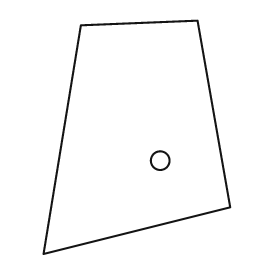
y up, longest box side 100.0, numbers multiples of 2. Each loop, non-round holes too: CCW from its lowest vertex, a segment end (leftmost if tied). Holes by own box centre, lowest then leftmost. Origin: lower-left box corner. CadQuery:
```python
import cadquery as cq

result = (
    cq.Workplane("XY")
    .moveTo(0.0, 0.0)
    .lineTo(80.0, 20.0)
    .lineTo(66.0, 100.0)
    .lineTo(16.0, 98.0)
    .close()
    .moveTo(50.0, 40.0)
    .circle(4.0)
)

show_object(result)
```